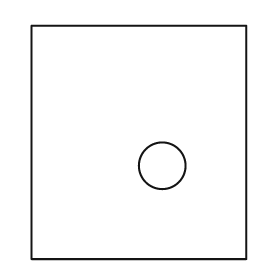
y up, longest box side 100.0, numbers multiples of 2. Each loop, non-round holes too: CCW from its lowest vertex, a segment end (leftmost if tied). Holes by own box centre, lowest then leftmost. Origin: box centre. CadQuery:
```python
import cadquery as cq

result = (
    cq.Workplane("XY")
    .moveTo(-46.0, -50.0)
    .lineTo(46.0, -50.0)
    .lineTo(46.0, 50.0)
    .lineTo(-46.0, 50.0)
    .close()
    .moveTo(10.0, -10.0)
    .circle(10.0)
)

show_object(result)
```